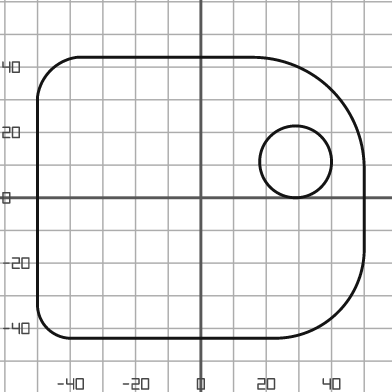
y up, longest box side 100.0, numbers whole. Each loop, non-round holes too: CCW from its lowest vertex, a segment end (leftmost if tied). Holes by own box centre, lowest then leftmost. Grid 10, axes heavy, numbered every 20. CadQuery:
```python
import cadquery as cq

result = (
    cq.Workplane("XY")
    .moveTo(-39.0, -43.0)
    .lineTo(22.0, -43.0)
    .threePointArc((42.0, -35.0), (50.0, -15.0))
    .lineTo(50.0, 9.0)
    .threePointArc((40.0, 33.0), (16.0, 43.0))
    .lineTo(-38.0, 43.0)
    .threePointArc((-46.0, 39.0), (-50.0, 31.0))
    .lineTo(-50.0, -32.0)
    .threePointArc((-47.0, -40.0), (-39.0, -43.0))
    .close()
    .moveTo(29.0, 11.0)
    .circle(11.0)
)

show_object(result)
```